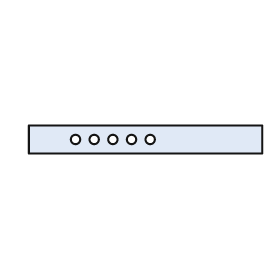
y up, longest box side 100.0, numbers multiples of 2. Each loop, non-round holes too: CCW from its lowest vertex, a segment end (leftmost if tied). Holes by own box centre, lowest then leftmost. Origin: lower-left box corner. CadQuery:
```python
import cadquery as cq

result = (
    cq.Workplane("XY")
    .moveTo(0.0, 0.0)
    .lineTo(100.0, 0.0)
    .lineTo(100.0, 12.0)
    .lineTo(0.0, 12.0)
    .close()
    .moveTo(20.0, 6.0)
    .circle(2.0)
    .moveTo(28.0, 6.0)
    .circle(2.0)
    .moveTo(36.0, 6.0)
    .circle(2.0)
    .moveTo(44.0, 6.0)
    .circle(2.0)
    .moveTo(52.0, 6.0)
    .circle(2.0)
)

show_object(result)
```